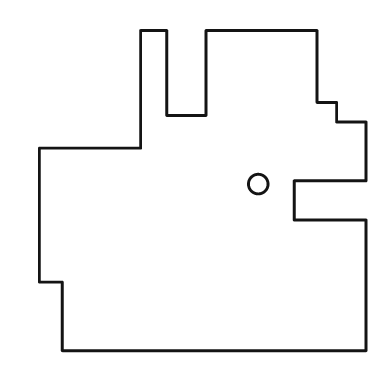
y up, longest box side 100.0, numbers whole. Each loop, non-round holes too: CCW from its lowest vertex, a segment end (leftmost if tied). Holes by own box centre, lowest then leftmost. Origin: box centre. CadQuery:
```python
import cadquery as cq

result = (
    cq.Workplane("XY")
    .moveTo(-43.0, -49.0)
    .lineTo(50.0, -49.0)
    .lineTo(50.0, -9.0)
    .lineTo(28.0, -9.0)
    .lineTo(28.0, 3.0)
    .lineTo(50.0, 3.0)
    .lineTo(50.0, 21.0)
    .lineTo(41.0, 21.0)
    .lineTo(41.0, 27.0)
    .lineTo(35.0, 27.0)
    .lineTo(35.0, 49.0)
    .lineTo(1.0, 49.0)
    .lineTo(1.0, 23.0)
    .lineTo(-11.0, 23.0)
    .lineTo(-11.0, 49.0)
    .lineTo(-19.0, 49.0)
    .lineTo(-19.0, 13.0)
    .lineTo(-50.0, 13.0)
    .lineTo(-50.0, -28.0)
    .lineTo(-43.0, -28.0)
    .close()
    .moveTo(17.0, 2.0)
    .circle(3.0)
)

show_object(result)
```